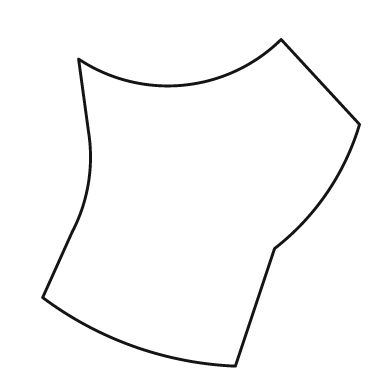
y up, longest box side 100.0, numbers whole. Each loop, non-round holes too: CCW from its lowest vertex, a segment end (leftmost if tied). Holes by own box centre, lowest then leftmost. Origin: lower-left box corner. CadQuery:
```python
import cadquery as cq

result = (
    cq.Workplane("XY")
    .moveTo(59.0, 0.0)
    .lineTo(71.0, 36.0)
    .threePointArc((87.0, 53.0), (97.0, 74.0))
    .lineTo(73.0, 100.0)
    .threePointArc((43.0, 86.0), (11.0, 94.0))
    .lineTo(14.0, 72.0)
    .threePointArc((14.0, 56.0), (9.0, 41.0))
    .lineTo(0.0, 21.0)
    .threePointArc((28.0, 6.0), (59.0, 0.0))
    .close()
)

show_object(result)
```